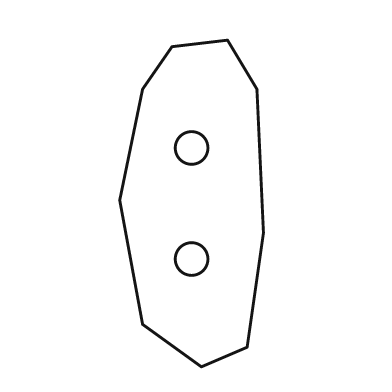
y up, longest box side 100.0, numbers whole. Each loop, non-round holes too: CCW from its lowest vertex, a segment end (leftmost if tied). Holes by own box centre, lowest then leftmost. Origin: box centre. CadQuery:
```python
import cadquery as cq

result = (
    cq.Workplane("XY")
    .moveTo(3.0, -50.0)
    .lineTo(17.0, -44.0)
    .lineTo(22.0, -9.0)
    .lineTo(20.0, 35.0)
    .lineTo(11.0, 50.0)
    .lineTo(-6.0, 48.0)
    .lineTo(-15.0, 35.0)
    .lineTo(-22.0, 1.0)
    .lineTo(-15.0, -37.0)
    .close()
    .moveTo(0.0, -17.0)
    .circle(5.0)
    .moveTo(0.0, 17.0)
    .circle(5.0)
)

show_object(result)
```